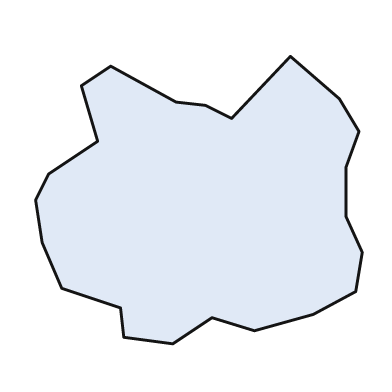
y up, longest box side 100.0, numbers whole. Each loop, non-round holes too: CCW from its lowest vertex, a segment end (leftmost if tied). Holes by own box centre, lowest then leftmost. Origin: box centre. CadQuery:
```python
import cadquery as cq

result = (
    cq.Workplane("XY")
    .moveTo(-8.0, -44.0)
    .lineTo(4.0, -36.0)
    .lineTo(17.0, -40.0)
    .lineTo(35.0, -35.0)
    .lineTo(48.0, -28.0)
    .lineTo(50.0, -16.0)
    .lineTo(45.0, -5.0)
    .lineTo(45.0, 10.0)
    .lineTo(49.0, 21.0)
    .lineTo(43.0, 31.0)
    .lineTo(28.0, 44.0)
    .lineTo(10.0, 25.0)
    .lineTo(2.0, 29.0)
    .lineTo(-7.0, 30.0)
    .lineTo(-27.0, 41.0)
    .lineTo(-36.0, 35.0)
    .lineTo(-31.0, 18.0)
    .lineTo(-46.0, 8.0)
    .lineTo(-50.0, 0.0)
    .lineTo(-48.0, -13.0)
    .lineTo(-42.0, -27.0)
    .lineTo(-24.0, -33.0)
    .lineTo(-23.0, -42.0)
    .close()
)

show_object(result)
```